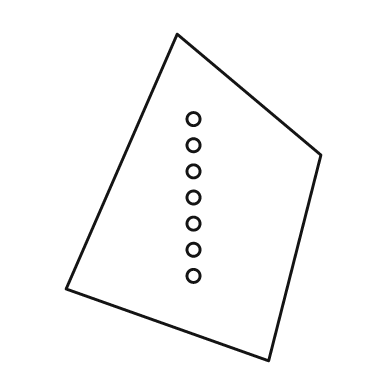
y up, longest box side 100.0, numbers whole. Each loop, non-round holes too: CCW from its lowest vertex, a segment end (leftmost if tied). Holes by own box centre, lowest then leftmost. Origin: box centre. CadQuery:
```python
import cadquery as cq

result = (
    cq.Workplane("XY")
    .moveTo(23.0, -50.0)
    .lineTo(39.0, 13.0)
    .lineTo(-5.0, 50.0)
    .lineTo(-39.0, -28.0)
    .close()
    .moveTo(0.0, -24.0)
    .circle(2.0)
    .moveTo(0.0, -16.0)
    .circle(2.0)
    .moveTo(0.0, -8.0)
    .circle(2.0)
    .moveTo(0.0, 0.0)
    .circle(2.0)
    .moveTo(0.0, 8.0)
    .circle(2.0)
    .moveTo(0.0, 16.0)
    .circle(2.0)
    .moveTo(0.0, 24.0)
    .circle(2.0)
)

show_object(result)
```